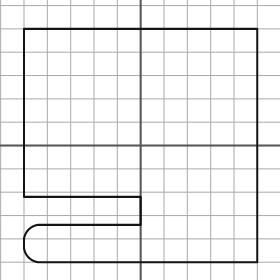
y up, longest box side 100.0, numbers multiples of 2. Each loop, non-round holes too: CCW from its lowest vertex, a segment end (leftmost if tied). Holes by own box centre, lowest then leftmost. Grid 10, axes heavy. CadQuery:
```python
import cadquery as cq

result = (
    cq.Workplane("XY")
    .moveTo(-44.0, -50.0)
    .lineTo(50.0, -50.0)
    .lineTo(50.0, 50.0)
    .lineTo(-50.0, 50.0)
    .lineTo(-50.0, -22.0)
    .lineTo(0.0, -22.0)
    .lineTo(0.0, -34.0)
    .lineTo(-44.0, -34.0)
    .threePointArc((-48.0, -36.0), (-50.0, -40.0))
    .lineTo(-50.0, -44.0)
    .threePointArc((-48.0, -48.0), (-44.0, -50.0))
    .close()
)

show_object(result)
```